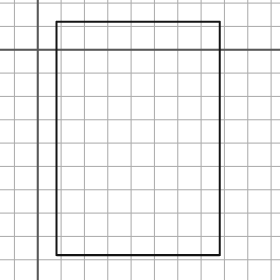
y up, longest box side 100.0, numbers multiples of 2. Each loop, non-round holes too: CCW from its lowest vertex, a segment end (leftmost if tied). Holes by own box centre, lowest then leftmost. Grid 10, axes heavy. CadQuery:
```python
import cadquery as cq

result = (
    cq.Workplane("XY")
    .moveTo(8.0, -88.0)
    .lineTo(78.0, -88.0)
    .lineTo(78.0, 12.0)
    .lineTo(8.0, 12.0)
    .close()
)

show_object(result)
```